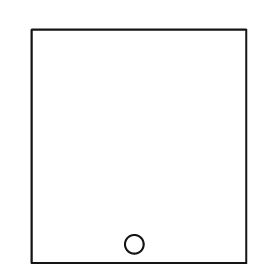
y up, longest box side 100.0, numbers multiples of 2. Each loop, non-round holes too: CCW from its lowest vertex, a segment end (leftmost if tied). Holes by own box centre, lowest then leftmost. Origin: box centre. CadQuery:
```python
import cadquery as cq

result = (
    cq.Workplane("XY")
    .moveTo(-46.0, -50.0)
    .lineTo(46.0, -50.0)
    .lineTo(46.0, 50.0)
    .lineTo(-46.0, 50.0)
    .close()
    .moveTo(-2.0, -42.0)
    .circle(4.0)
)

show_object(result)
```